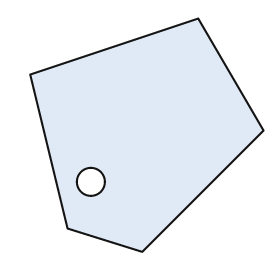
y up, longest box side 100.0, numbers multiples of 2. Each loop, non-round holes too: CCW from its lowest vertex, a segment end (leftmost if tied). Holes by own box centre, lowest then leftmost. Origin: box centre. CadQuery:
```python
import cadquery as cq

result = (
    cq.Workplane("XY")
    .moveTo(-2.0, -50.0)
    .lineTo(50.0, 2.0)
    .lineTo(22.0, 50.0)
    .lineTo(-50.0, 26.0)
    .lineTo(-34.0, -40.0)
    .close()
    .moveTo(-24.0, -20.0)
    .circle(6.0)
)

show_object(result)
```